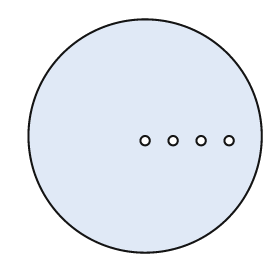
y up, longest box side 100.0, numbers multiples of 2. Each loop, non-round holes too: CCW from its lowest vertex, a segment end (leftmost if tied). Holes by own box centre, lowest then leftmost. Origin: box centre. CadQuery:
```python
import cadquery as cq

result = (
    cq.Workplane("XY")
    .moveTo(0.0, 0.0)
    .circle(50.0)
    .moveTo(0.0, -2.0)
    .circle(2.0)
    .moveTo(12.0, -2.0)
    .circle(2.0)
    .moveTo(24.0, -2.0)
    .circle(2.0)
    .moveTo(36.0, -2.0)
    .circle(2.0)
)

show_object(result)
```